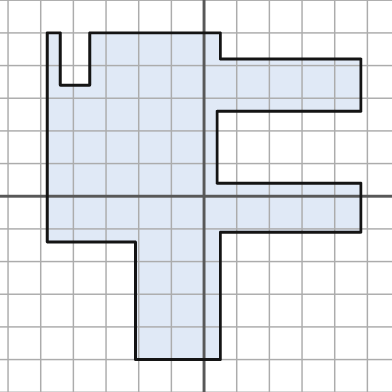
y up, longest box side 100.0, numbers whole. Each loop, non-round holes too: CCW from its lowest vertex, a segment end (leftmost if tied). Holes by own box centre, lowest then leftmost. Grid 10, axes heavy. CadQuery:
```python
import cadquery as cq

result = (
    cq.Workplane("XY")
    .moveTo(-21.0, -50.0)
    .lineTo(5.0, -50.0)
    .lineTo(5.0, -11.0)
    .lineTo(48.0, -11.0)
    .lineTo(48.0, 4.0)
    .lineTo(4.0, 4.0)
    .lineTo(4.0, 26.0)
    .lineTo(48.0, 26.0)
    .lineTo(48.0, 42.0)
    .lineTo(5.0, 42.0)
    .lineTo(5.0, 50.0)
    .lineTo(-35.0, 50.0)
    .lineTo(-35.0, 34.0)
    .lineTo(-44.0, 34.0)
    .lineTo(-44.0, 50.0)
    .lineTo(-48.0, 50.0)
    .lineTo(-48.0, -14.0)
    .lineTo(-21.0, -14.0)
    .close()
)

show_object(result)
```